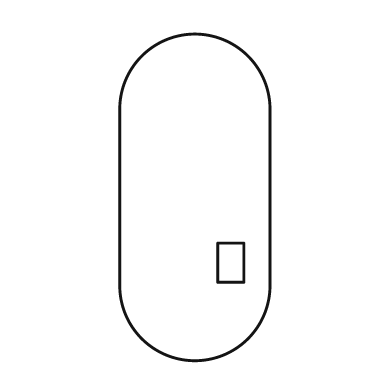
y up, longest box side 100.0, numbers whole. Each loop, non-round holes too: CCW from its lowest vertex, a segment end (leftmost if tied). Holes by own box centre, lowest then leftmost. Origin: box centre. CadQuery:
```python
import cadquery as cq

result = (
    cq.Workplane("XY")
    .moveTo(-23.0, -27.0)
    .threePointArc((0.0, -50.0), (23.0, -27.0))
    .lineTo(23.0, 27.0)
    .threePointArc((0.0, 50.0), (-23.0, 27.0))
    .close()
    .moveTo(7.0, -26.0)
    .lineTo(15.0, -26.0)
    .lineTo(15.0, -14.0)
    .lineTo(7.0, -14.0)
    .close()
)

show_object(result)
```